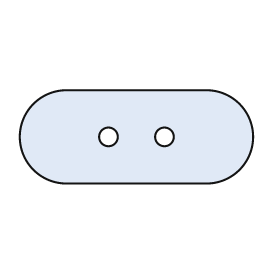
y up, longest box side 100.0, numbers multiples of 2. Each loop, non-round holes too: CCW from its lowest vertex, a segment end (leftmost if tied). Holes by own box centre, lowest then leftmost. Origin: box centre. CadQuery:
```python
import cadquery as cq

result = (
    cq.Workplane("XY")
    .moveTo(-30.0, -20.0)
    .lineTo(30.0, -20.0)
    .threePointArc((50.0, 0.0), (30.0, 20.0))
    .lineTo(-30.0, 20.0)
    .threePointArc((-50.0, 0.0), (-30.0, -20.0))
    .close()
    .moveTo(-12.0, 0.0)
    .circle(4.0)
    .moveTo(12.0, 0.0)
    .circle(4.0)
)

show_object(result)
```